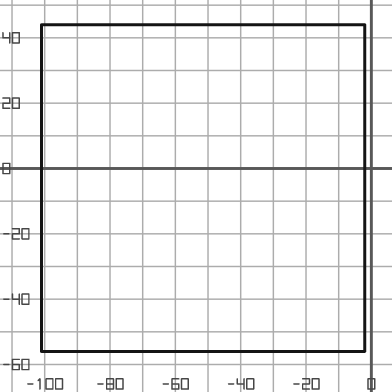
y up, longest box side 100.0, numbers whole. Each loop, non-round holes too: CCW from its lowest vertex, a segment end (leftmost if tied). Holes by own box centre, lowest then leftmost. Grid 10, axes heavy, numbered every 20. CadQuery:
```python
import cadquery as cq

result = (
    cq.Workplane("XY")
    .moveTo(-101.0, -56.0)
    .lineTo(-2.0, -56.0)
    .lineTo(-2.0, 44.0)
    .lineTo(-101.0, 44.0)
    .close()
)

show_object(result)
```